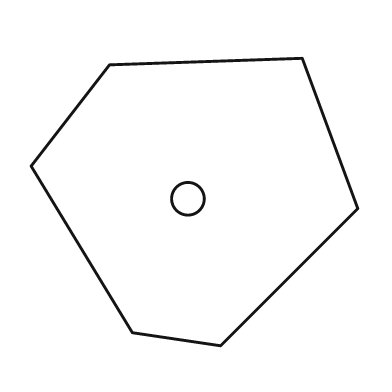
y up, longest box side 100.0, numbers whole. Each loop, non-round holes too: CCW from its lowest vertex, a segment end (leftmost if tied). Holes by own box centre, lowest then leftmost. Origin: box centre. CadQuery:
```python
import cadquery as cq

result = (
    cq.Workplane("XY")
    .moveTo(8.0, -44.0)
    .lineTo(50.0, -2.0)
    .lineTo(33.0, 44.0)
    .lineTo(-26.0, 42.0)
    .lineTo(-50.0, 11.0)
    .lineTo(-19.0, -40.0)
    .close()
    .moveTo(-2.0, 1.0)
    .circle(5.0)
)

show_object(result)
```